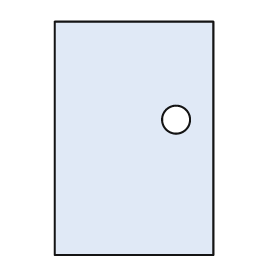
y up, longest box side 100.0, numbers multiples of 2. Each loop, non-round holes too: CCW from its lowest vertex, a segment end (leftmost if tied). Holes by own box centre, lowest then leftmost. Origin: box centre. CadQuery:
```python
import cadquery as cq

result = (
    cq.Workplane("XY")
    .moveTo(-34.0, -50.0)
    .lineTo(34.0, -50.0)
    .lineTo(34.0, 50.0)
    .lineTo(-34.0, 50.0)
    .close()
    .moveTo(18.0, 8.0)
    .circle(6.0)
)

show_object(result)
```